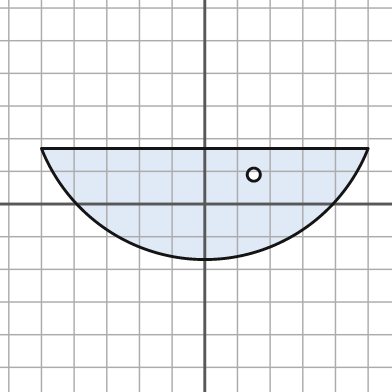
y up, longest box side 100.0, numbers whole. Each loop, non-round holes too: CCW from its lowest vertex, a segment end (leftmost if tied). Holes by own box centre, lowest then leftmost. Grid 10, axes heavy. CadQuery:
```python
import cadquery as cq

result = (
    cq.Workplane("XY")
    .moveTo(-50.0, 17.0)
    .threePointArc((0.0, -17.0), (50.0, 17.0))
    .close()
    .moveTo(15.0, 9.0)
    .circle(2.0)
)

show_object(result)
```